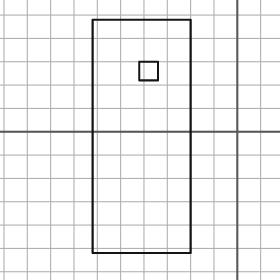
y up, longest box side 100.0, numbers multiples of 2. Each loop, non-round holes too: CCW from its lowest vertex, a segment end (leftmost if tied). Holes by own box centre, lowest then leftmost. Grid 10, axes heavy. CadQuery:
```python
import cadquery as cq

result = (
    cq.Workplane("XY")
    .moveTo(-62.0, -52.0)
    .lineTo(-20.0, -52.0)
    .lineTo(-20.0, 48.0)
    .lineTo(-62.0, 48.0)
    .close()
    .moveTo(-42.0, 22.0)
    .lineTo(-34.0, 22.0)
    .lineTo(-34.0, 30.0)
    .lineTo(-42.0, 30.0)
    .close()
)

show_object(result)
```